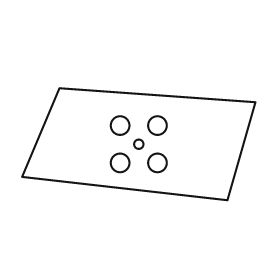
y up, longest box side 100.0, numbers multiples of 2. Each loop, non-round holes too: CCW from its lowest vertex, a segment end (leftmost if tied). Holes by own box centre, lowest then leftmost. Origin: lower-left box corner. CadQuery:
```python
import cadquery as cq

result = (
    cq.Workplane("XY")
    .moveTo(88.0, 0.0)
    .lineTo(100.0, 42.0)
    .lineTo(16.0, 48.0)
    .lineTo(0.0, 10.0)
    .close()
    .moveTo(42.0, 16.0)
    .circle(4.0)
    .moveTo(58.0, 16.0)
    .circle(4.0)
    .moveTo(50.0, 24.0)
    .circle(2.0)
    .moveTo(42.0, 32.0)
    .circle(4.0)
    .moveTo(58.0, 32.0)
    .circle(4.0)
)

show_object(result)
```